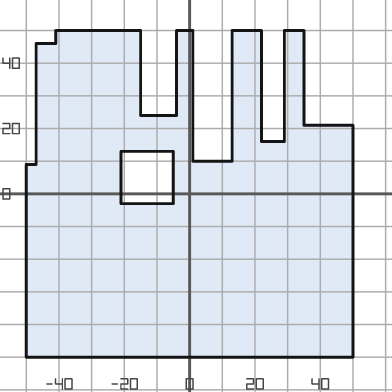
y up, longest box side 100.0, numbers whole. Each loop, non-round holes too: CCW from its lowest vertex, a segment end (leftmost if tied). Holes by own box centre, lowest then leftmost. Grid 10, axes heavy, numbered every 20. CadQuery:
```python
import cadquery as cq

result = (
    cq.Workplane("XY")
    .moveTo(-50.0, -50.0)
    .lineTo(50.0, -50.0)
    .lineTo(50.0, 21.0)
    .lineTo(35.0, 21.0)
    .lineTo(35.0, 50.0)
    .lineTo(29.0, 50.0)
    .lineTo(29.0, 16.0)
    .lineTo(22.0, 16.0)
    .lineTo(22.0, 50.0)
    .lineTo(13.0, 50.0)
    .lineTo(13.0, 10.0)
    .lineTo(1.0, 10.0)
    .lineTo(1.0, 50.0)
    .lineTo(-4.0, 50.0)
    .lineTo(-4.0, 24.0)
    .lineTo(-15.0, 24.0)
    .lineTo(-15.0, 50.0)
    .lineTo(-41.0, 50.0)
    .lineTo(-41.0, 46.0)
    .lineTo(-47.0, 46.0)
    .lineTo(-47.0, 9.0)
    .lineTo(-50.0, 9.0)
    .close()
    .moveTo(-21.0, -3.0)
    .lineTo(-5.0, -3.0)
    .lineTo(-5.0, 13.0)
    .lineTo(-21.0, 13.0)
    .close()
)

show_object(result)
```